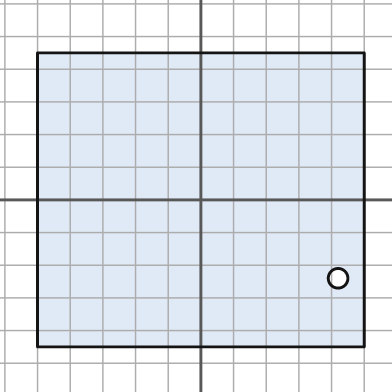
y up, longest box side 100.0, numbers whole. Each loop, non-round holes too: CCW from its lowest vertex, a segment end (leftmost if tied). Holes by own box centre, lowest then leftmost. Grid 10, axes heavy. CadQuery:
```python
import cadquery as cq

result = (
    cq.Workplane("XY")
    .moveTo(-50.0, -45.0)
    .lineTo(50.0, -45.0)
    .lineTo(50.0, 45.0)
    .lineTo(-50.0, 45.0)
    .close()
    .moveTo(42.0, -24.0)
    .circle(3.0)
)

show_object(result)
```